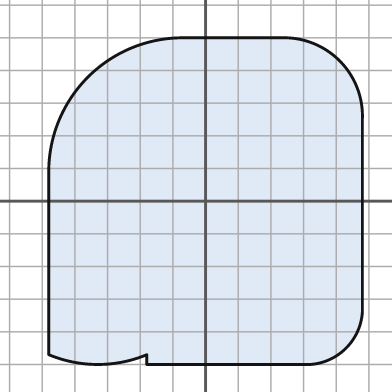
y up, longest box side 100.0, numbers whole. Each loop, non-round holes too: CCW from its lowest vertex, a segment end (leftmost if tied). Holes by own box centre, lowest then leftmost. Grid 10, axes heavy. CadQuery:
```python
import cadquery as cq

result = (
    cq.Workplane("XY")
    .moveTo(-18.0, -50.0)
    .lineTo(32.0, -50.0)
    .threePointArc((43.0, -45.0), (48.0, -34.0))
    .lineTo(48.0, 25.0)
    .threePointArc((41.0, 43.0), (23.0, 50.0))
    .lineTo(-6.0, 50.0)
    .threePointArc((-36.0, 38.0), (-48.0, 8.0))
    .lineTo(-48.0, -47.0)
    .threePointArc((-33.0, -50.0), (-18.0, -47.0))
    .close()
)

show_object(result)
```